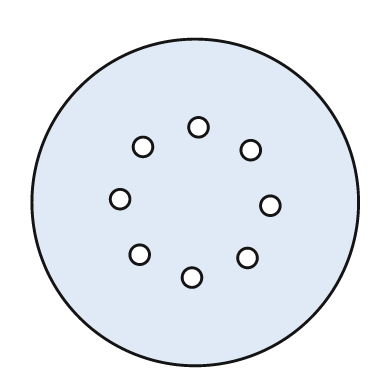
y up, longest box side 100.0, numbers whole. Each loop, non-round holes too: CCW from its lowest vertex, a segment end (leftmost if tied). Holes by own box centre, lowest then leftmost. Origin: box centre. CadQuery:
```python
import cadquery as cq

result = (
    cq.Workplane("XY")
    .moveTo(0.0, 0.0)
    .circle(50.0)
    .moveTo(-1.0, -23.0)
    .circle(3.0)
    .moveTo(16.0, -17.0)
    .circle(3.0)
    .moveTo(-17.0, -16.0)
    .circle(3.0)
    .moveTo(23.0, -1.0)
    .circle(3.0)
    .moveTo(-23.0, 1.0)
    .circle(3.0)
    .moveTo(17.0, 16.0)
    .circle(3.0)
    .moveTo(-16.0, 17.0)
    .circle(3.0)
    .moveTo(1.0, 23.0)
    .circle(3.0)
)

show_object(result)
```